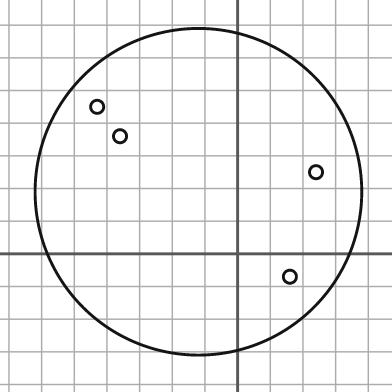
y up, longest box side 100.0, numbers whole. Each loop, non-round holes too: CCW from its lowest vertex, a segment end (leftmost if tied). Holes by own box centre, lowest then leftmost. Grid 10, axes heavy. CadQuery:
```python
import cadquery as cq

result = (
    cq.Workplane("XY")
    .moveTo(-12.0, 19.0)
    .circle(50.0)
    .moveTo(16.0, -7.0)
    .circle(2.0)
    .moveTo(24.0, 25.0)
    .circle(2.0)
    .moveTo(-36.0, 36.0)
    .circle(2.0)
    .moveTo(-43.0, 45.0)
    .circle(2.0)
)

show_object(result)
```